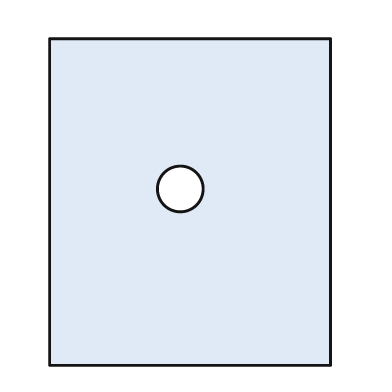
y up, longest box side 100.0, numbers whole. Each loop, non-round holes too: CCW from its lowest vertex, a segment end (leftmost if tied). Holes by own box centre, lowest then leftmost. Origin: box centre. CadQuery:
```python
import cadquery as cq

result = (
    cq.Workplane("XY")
    .moveTo(-43.0, -50.0)
    .lineTo(43.0, -50.0)
    .lineTo(43.0, 50.0)
    .lineTo(-43.0, 50.0)
    .close()
    .moveTo(-3.0, 4.0)
    .circle(7.0)
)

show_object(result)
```